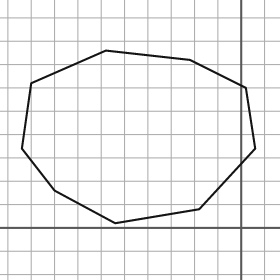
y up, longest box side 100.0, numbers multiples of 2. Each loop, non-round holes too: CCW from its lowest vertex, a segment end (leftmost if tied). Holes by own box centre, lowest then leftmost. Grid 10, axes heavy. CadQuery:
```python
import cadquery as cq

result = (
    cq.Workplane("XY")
    .moveTo(-54.0, 2.0)
    .lineTo(-18.0, 8.0)
    .lineTo(6.0, 34.0)
    .lineTo(2.0, 60.0)
    .lineTo(-22.0, 72.0)
    .lineTo(-58.0, 76.0)
    .lineTo(-90.0, 62.0)
    .lineTo(-94.0, 34.0)
    .lineTo(-80.0, 16.0)
    .close()
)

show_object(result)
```